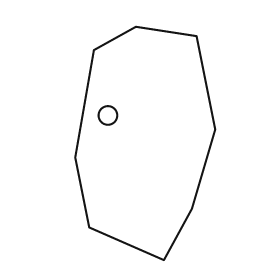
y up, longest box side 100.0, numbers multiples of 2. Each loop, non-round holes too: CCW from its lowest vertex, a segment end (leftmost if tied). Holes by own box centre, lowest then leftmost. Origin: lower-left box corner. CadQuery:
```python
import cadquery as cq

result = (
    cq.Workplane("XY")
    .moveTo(38.0, 0.0)
    .lineTo(50.0, 22.0)
    .lineTo(60.0, 56.0)
    .lineTo(52.0, 96.0)
    .lineTo(26.0, 100.0)
    .lineTo(8.0, 90.0)
    .lineTo(0.0, 44.0)
    .lineTo(6.0, 14.0)
    .close()
    .moveTo(14.0, 62.0)
    .circle(4.0)
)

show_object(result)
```